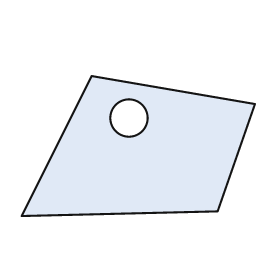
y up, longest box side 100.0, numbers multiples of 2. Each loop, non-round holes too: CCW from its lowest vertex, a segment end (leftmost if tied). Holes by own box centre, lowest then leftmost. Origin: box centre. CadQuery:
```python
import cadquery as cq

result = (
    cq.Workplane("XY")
    .moveTo(-50.0, -30.0)
    .lineTo(34.0, -28.0)
    .lineTo(50.0, 18.0)
    .lineTo(-20.0, 30.0)
    .close()
    .moveTo(-4.0, 12.0)
    .circle(8.0)
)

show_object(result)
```